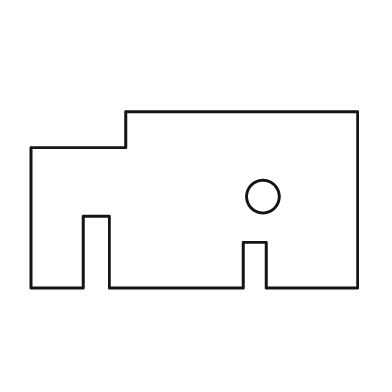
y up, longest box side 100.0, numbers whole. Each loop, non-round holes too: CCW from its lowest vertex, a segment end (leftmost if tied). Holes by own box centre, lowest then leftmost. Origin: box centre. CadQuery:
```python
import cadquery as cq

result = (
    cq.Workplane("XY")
    .moveTo(-50.0, -27.0)
    .lineTo(-34.0, -27.0)
    .lineTo(-34.0, -5.0)
    .lineTo(-26.0, -5.0)
    .lineTo(-26.0, -27.0)
    .lineTo(15.0, -27.0)
    .lineTo(15.0, -13.0)
    .lineTo(22.0, -13.0)
    .lineTo(22.0, -27.0)
    .lineTo(50.0, -27.0)
    .lineTo(50.0, 27.0)
    .lineTo(-21.0, 27.0)
    .lineTo(-21.0, 16.0)
    .lineTo(-50.0, 16.0)
    .close()
    .moveTo(21.0, 1.0)
    .circle(5.0)
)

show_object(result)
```